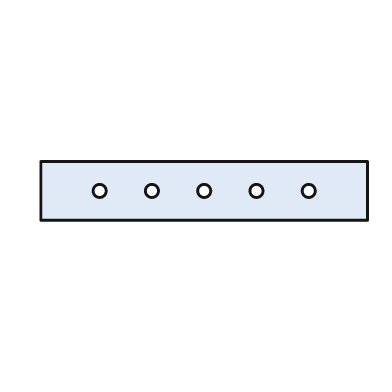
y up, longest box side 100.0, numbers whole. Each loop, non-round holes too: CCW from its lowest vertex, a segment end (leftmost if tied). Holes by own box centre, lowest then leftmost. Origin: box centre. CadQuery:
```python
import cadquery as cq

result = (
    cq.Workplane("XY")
    .moveTo(-50.0, -9.0)
    .lineTo(50.0, -9.0)
    .lineTo(50.0, 9.0)
    .lineTo(-50.0, 9.0)
    .close()
    .moveTo(-32.0, 0.0)
    .circle(2.0)
    .moveTo(-16.0, 0.0)
    .circle(2.0)
    .moveTo(0.0, 0.0)
    .circle(2.0)
    .moveTo(16.0, 0.0)
    .circle(2.0)
    .moveTo(32.0, 0.0)
    .circle(2.0)
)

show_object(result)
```